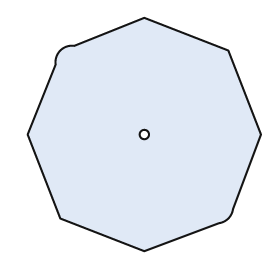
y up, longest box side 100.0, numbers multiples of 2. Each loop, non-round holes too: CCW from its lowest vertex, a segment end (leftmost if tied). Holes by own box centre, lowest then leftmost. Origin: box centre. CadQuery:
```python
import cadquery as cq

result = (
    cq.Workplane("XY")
    .moveTo(0.0, -50.0)
    .lineTo(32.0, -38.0)
    .threePointArc((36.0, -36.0), (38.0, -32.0))
    .lineTo(50.0, 0.0)
    .lineTo(36.0, 36.0)
    .lineTo(0.0, 50.0)
    .lineTo(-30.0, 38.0)
    .threePointArc((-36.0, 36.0), (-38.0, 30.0))
    .lineTo(-50.0, 0.0)
    .lineTo(-36.0, -36.0)
    .close()
    .moveTo(0.0, 0.0)
    .circle(2.0)
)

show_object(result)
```